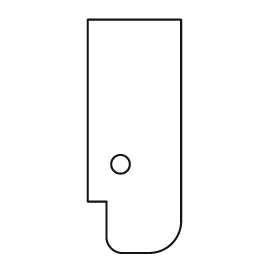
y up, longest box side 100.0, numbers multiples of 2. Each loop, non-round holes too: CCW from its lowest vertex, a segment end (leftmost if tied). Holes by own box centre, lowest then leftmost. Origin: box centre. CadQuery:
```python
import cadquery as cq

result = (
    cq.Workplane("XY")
    .moveTo(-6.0, -50.0)
    .lineTo(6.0, -50.0)
    .threePointArc((16.0, -46.0), (20.0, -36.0))
    .lineTo(20.0, 50.0)
    .lineTo(-20.0, 50.0)
    .lineTo(-20.0, -28.0)
    .lineTo(-12.0, -28.0)
    .lineTo(-12.0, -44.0)
    .threePointArc((-10.0, -48.0), (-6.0, -50.0))
    .close()
    .moveTo(-6.0, -12.0)
    .circle(4.0)
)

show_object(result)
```